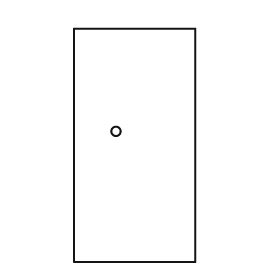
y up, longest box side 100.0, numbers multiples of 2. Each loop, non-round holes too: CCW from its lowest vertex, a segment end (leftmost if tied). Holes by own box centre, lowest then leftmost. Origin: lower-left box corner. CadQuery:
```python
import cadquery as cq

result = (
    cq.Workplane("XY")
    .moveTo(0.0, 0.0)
    .lineTo(52.0, 0.0)
    .lineTo(52.0, 100.0)
    .lineTo(0.0, 100.0)
    .close()
    .moveTo(18.0, 56.0)
    .circle(2.0)
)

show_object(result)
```